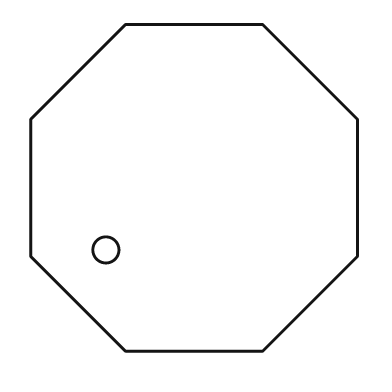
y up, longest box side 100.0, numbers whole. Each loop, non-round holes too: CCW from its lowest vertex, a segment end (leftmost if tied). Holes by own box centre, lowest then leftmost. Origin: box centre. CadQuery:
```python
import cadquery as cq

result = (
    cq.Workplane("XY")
    .moveTo(-21.0, -50.0)
    .lineTo(21.0, -50.0)
    .lineTo(50.0, -21.0)
    .lineTo(50.0, 21.0)
    .lineTo(21.0, 50.0)
    .lineTo(-21.0, 50.0)
    .lineTo(-50.0, 21.0)
    .lineTo(-50.0, -21.0)
    .close()
    .moveTo(-27.0, -19.0)
    .circle(4.0)
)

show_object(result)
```